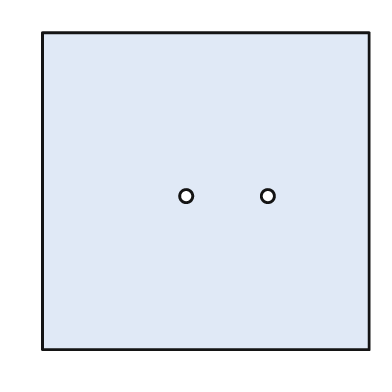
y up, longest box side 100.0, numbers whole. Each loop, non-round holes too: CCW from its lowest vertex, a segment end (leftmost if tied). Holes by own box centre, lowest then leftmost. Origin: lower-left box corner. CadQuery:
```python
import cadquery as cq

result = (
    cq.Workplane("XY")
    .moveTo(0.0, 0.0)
    .lineTo(100.0, 0.0)
    .lineTo(100.0, 97.0)
    .lineTo(0.0, 97.0)
    .close()
    .moveTo(44.0, 47.0)
    .circle(2.0)
    .moveTo(69.0, 47.0)
    .circle(2.0)
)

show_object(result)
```